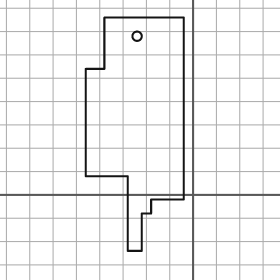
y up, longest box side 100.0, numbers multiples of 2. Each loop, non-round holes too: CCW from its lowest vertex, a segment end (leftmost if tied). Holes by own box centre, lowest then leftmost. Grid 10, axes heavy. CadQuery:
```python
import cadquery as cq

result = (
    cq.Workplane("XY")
    .moveTo(-28.0, -24.0)
    .lineTo(-22.0, -24.0)
    .lineTo(-22.0, -8.0)
    .lineTo(-18.0, -8.0)
    .lineTo(-18.0, -2.0)
    .lineTo(-4.0, -2.0)
    .lineTo(-4.0, 76.0)
    .lineTo(-38.0, 76.0)
    .lineTo(-38.0, 54.0)
    .lineTo(-46.0, 54.0)
    .lineTo(-46.0, 8.0)
    .lineTo(-28.0, 8.0)
    .close()
    .moveTo(-24.0, 68.0)
    .circle(2.0)
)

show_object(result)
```